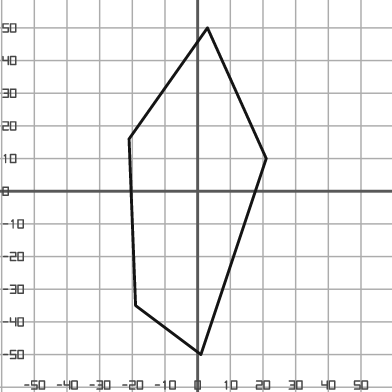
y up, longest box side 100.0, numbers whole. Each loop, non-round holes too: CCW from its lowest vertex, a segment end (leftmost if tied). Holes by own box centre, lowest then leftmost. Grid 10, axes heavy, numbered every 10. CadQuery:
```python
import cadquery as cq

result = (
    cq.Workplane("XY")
    .moveTo(1.0, -50.0)
    .lineTo(21.0, 10.0)
    .lineTo(3.0, 50.0)
    .lineTo(-21.0, 16.0)
    .lineTo(-19.0, -35.0)
    .close()
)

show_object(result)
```